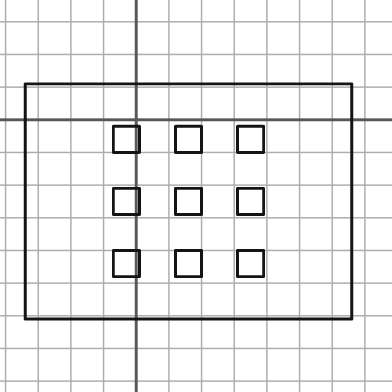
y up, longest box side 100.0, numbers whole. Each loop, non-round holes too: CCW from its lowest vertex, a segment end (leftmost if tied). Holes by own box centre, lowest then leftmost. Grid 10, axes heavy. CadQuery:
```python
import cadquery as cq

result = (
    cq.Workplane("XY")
    .moveTo(-34.0, -61.0)
    .lineTo(66.0, -61.0)
    .lineTo(66.0, 11.0)
    .lineTo(-34.0, 11.0)
    .close()
    .moveTo(-7.0, -48.0)
    .lineTo(1.0, -48.0)
    .lineTo(1.0, -40.0)
    .lineTo(-7.0, -40.0)
    .close()
    .moveTo(12.0, -48.0)
    .lineTo(20.0, -48.0)
    .lineTo(20.0, -40.0)
    .lineTo(12.0, -40.0)
    .close()
    .moveTo(31.0, -48.0)
    .lineTo(39.0, -48.0)
    .lineTo(39.0, -40.0)
    .lineTo(31.0, -40.0)
    .close()
    .moveTo(-7.0, -29.0)
    .lineTo(1.0, -29.0)
    .lineTo(1.0, -21.0)
    .lineTo(-7.0, -21.0)
    .close()
    .moveTo(12.0, -29.0)
    .lineTo(20.0, -29.0)
    .lineTo(20.0, -21.0)
    .lineTo(12.0, -21.0)
    .close()
    .moveTo(31.0, -29.0)
    .lineTo(39.0, -29.0)
    .lineTo(39.0, -21.0)
    .lineTo(31.0, -21.0)
    .close()
    .moveTo(-7.0, -10.0)
    .lineTo(1.0, -10.0)
    .lineTo(1.0, -2.0)
    .lineTo(-7.0, -2.0)
    .close()
    .moveTo(12.0, -10.0)
    .lineTo(20.0, -10.0)
    .lineTo(20.0, -2.0)
    .lineTo(12.0, -2.0)
    .close()
    .moveTo(31.0, -10.0)
    .lineTo(39.0, -10.0)
    .lineTo(39.0, -2.0)
    .lineTo(31.0, -2.0)
    .close()
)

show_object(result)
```